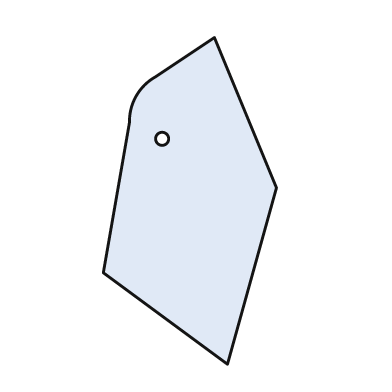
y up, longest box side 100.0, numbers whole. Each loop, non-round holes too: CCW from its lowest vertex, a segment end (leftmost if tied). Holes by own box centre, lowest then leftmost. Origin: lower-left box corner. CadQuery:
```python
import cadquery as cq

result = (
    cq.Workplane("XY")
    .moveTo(38.0, 0.0)
    .lineTo(53.0, 54.0)
    .lineTo(34.0, 100.0)
    .lineTo(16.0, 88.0)
    .threePointArc((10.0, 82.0), (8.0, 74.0))
    .lineTo(0.0, 28.0)
    .close()
    .moveTo(18.0, 69.0)
    .circle(2.0)
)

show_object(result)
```